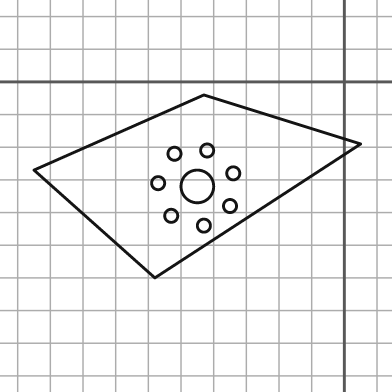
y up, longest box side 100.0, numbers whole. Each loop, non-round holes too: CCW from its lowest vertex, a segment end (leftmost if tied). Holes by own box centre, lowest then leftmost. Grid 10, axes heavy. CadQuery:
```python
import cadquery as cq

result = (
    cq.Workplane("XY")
    .moveTo(-58.0, -60.0)
    .lineTo(5.0, -19.0)
    .lineTo(-43.0, -4.0)
    .lineTo(-95.0, -27.0)
    .close()
    .moveTo(-43.0, -44.0)
    .circle(2.0)
    .moveTo(-53.0, -41.0)
    .circle(2.0)
    .moveTo(-35.0, -38.0)
    .circle(2.0)
    .moveTo(-45.0, -32.0)
    .circle(5.0)
    .moveTo(-57.0, -31.0)
    .circle(2.0)
    .moveTo(-34.0, -28.0)
    .circle(2.0)
    .moveTo(-52.0, -22.0)
    .circle(2.0)
    .moveTo(-42.0, -21.0)
    .circle(2.0)
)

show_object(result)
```